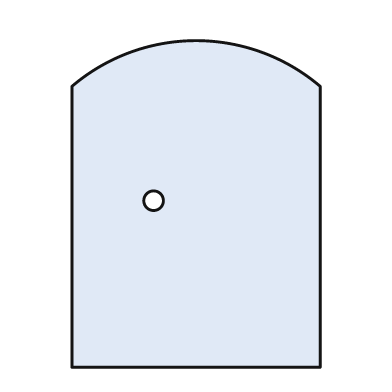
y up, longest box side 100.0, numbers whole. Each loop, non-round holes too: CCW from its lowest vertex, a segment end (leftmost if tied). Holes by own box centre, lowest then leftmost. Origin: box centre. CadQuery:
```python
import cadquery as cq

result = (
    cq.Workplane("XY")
    .moveTo(-38.0, -50.0)
    .lineTo(38.0, -50.0)
    .lineTo(38.0, 36.0)
    .threePointArc((0.0, 50.0), (-38.0, 36.0))
    .close()
    .moveTo(-13.0, 1.0)
    .circle(3.0)
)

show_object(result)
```